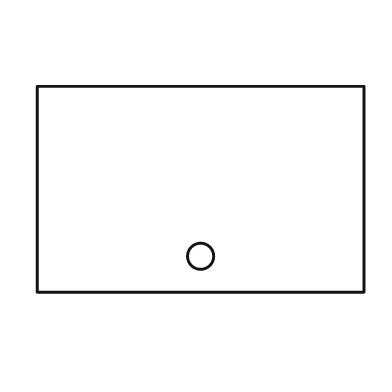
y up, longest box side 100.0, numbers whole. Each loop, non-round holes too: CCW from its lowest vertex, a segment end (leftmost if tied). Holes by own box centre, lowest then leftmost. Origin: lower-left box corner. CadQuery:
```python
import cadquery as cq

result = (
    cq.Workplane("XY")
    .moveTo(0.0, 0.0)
    .lineTo(100.0, 0.0)
    .lineTo(100.0, 63.0)
    .lineTo(0.0, 63.0)
    .close()
    .moveTo(50.0, 11.0)
    .circle(4.0)
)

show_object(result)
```